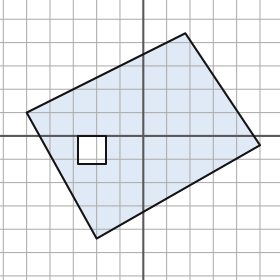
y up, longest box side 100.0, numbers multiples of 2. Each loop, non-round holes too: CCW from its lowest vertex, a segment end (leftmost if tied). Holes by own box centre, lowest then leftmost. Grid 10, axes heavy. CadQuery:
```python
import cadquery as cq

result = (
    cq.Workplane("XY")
    .moveTo(-20.0, -44.0)
    .lineTo(50.0, -4.0)
    .lineTo(18.0, 44.0)
    .lineTo(-50.0, 10.0)
    .close()
    .moveTo(-28.0, -12.0)
    .lineTo(-16.0, -12.0)
    .lineTo(-16.0, 0.0)
    .lineTo(-28.0, 0.0)
    .close()
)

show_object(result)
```